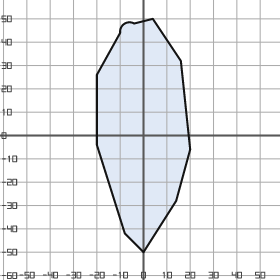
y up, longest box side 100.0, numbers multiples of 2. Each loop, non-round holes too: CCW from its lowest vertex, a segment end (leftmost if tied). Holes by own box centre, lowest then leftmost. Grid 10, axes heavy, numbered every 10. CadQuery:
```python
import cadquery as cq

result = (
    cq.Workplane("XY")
    .moveTo(0.0, -50.0)
    .lineTo(14.0, -28.0)
    .lineTo(20.0, -6.0)
    .lineTo(16.0, 32.0)
    .lineTo(4.0, 50.0)
    .lineTo(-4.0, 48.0)
    .threePointArc((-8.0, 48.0), (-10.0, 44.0))
    .lineTo(-20.0, 26.0)
    .lineTo(-20.0, -4.0)
    .lineTo(-8.0, -42.0)
    .close()
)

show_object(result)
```